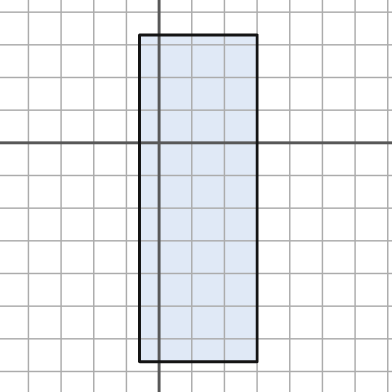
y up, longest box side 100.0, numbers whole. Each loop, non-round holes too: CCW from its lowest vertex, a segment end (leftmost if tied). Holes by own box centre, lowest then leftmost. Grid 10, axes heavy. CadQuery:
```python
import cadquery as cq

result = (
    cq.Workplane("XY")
    .moveTo(-6.0, -67.0)
    .lineTo(30.0, -67.0)
    .lineTo(30.0, 33.0)
    .lineTo(-6.0, 33.0)
    .close()
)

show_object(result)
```